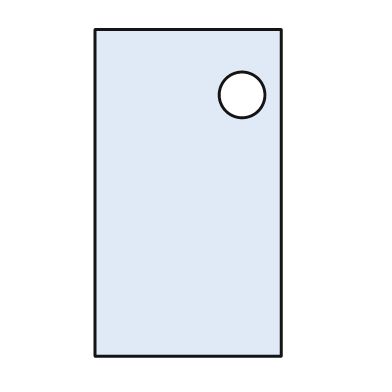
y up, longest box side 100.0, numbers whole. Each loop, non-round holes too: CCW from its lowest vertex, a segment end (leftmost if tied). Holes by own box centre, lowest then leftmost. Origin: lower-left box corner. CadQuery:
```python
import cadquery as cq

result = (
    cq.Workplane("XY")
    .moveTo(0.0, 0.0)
    .lineTo(57.0, 0.0)
    .lineTo(57.0, 100.0)
    .lineTo(0.0, 100.0)
    .close()
    .moveTo(45.0, 80.0)
    .circle(7.0)
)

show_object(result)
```